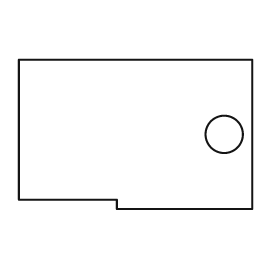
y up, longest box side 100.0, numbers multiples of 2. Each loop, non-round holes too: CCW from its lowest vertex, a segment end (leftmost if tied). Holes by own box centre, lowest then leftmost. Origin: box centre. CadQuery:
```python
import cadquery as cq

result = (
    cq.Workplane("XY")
    .moveTo(-8.0, -32.0)
    .lineTo(50.0, -32.0)
    .lineTo(50.0, 32.0)
    .lineTo(-50.0, 32.0)
    .lineTo(-50.0, -28.0)
    .lineTo(-8.0, -28.0)
    .close()
    .moveTo(38.0, 0.0)
    .circle(8.0)
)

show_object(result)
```